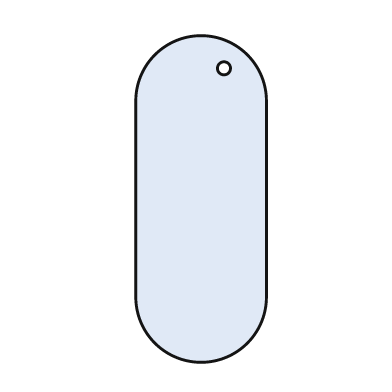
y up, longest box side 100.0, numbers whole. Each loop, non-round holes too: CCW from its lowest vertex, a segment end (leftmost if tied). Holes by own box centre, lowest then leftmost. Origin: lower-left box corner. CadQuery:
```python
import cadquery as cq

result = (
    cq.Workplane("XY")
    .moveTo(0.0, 20.0)
    .threePointArc((20.0, 0.0), (40.0, 20.0))
    .lineTo(40.0, 80.0)
    .threePointArc((20.0, 100.0), (0.0, 80.0))
    .close()
    .moveTo(27.0, 90.0)
    .circle(2.0)
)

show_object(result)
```